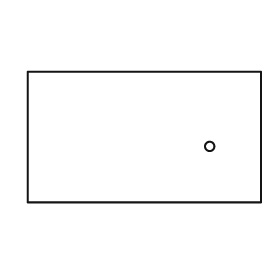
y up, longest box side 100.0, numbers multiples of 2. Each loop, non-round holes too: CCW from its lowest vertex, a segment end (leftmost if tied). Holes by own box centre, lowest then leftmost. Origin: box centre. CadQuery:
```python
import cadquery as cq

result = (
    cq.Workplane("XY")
    .moveTo(-50.0, -28.0)
    .lineTo(50.0, -28.0)
    .lineTo(50.0, 28.0)
    .lineTo(-50.0, 28.0)
    .close()
    .moveTo(28.0, -4.0)
    .circle(2.0)
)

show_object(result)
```